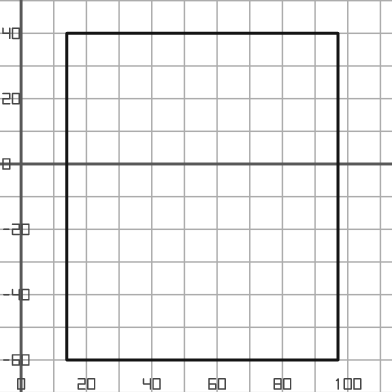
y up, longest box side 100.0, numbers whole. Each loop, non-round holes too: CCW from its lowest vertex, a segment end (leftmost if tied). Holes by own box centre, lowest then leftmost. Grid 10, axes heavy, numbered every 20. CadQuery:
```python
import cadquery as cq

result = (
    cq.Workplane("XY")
    .moveTo(14.0, -60.0)
    .lineTo(97.0, -60.0)
    .lineTo(97.0, 40.0)
    .lineTo(14.0, 40.0)
    .close()
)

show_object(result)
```